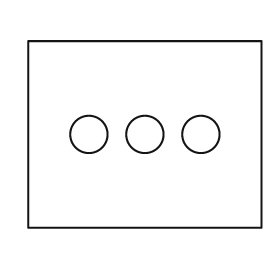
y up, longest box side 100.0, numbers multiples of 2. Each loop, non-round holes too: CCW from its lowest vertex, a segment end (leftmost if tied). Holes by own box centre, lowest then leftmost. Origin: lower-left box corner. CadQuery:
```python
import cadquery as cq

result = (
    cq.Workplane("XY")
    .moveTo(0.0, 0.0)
    .lineTo(100.0, 0.0)
    .lineTo(100.0, 80.0)
    .lineTo(0.0, 80.0)
    .close()
    .moveTo(26.0, 40.0)
    .circle(8.0)
    .moveTo(50.0, 40.0)
    .circle(8.0)
    .moveTo(74.0, 40.0)
    .circle(8.0)
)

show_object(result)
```